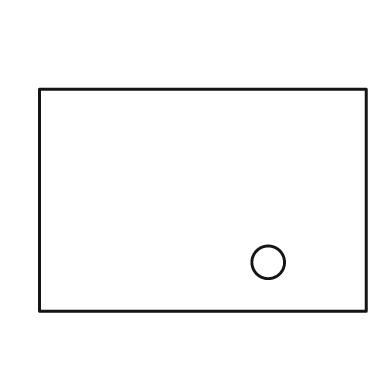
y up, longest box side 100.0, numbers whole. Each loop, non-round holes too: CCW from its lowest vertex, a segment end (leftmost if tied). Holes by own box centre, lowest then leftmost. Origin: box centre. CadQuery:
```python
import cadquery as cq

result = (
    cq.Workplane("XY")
    .moveTo(-50.0, -34.0)
    .lineTo(50.0, -34.0)
    .lineTo(50.0, 34.0)
    .lineTo(-50.0, 34.0)
    .close()
    .moveTo(20.0, -19.0)
    .circle(5.0)
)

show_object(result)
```